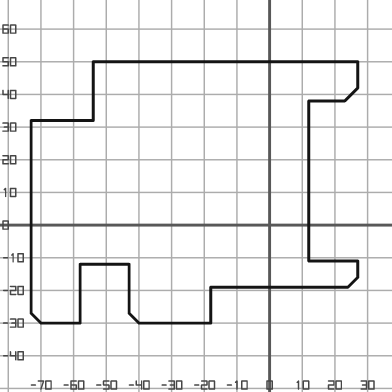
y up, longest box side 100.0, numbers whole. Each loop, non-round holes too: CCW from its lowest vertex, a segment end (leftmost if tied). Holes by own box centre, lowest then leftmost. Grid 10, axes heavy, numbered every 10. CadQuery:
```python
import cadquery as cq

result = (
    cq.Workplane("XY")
    .moveTo(-70.0, -30.0)
    .lineTo(-58.0, -30.0)
    .lineTo(-58.0, -12.0)
    .lineTo(-43.0, -12.0)
    .lineTo(-43.0, -27.0)
    .lineTo(-40.0, -30.0)
    .lineTo(-18.0, -30.0)
    .lineTo(-18.0, -19.0)
    .lineTo(24.0, -19.0)
    .lineTo(27.0, -16.0)
    .lineTo(27.0, -11.0)
    .lineTo(12.0, -11.0)
    .lineTo(12.0, 38.0)
    .lineTo(23.0, 38.0)
    .lineTo(27.0, 42.0)
    .lineTo(27.0, 50.0)
    .lineTo(-54.0, 50.0)
    .lineTo(-54.0, 32.0)
    .lineTo(-73.0, 32.0)
    .lineTo(-73.0, -27.0)
    .close()
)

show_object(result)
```